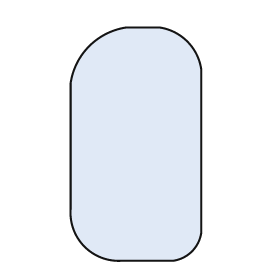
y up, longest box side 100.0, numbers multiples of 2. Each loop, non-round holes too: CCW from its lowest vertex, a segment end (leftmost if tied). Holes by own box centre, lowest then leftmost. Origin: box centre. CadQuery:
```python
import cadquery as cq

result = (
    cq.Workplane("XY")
    .moveTo(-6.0, -50.0)
    .lineTo(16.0, -50.0)
    .threePointArc((24.0, -46.0), (28.0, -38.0))
    .lineTo(28.0, 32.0)
    .threePointArc((22.0, 44.0), (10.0, 50.0))
    .lineTo(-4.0, 50.0)
    .threePointArc((-20.0, 42.0), (-28.0, 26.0))
    .lineTo(-28.0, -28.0)
    .threePointArc((-22.0, -44.0), (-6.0, -50.0))
    .close()
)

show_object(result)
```